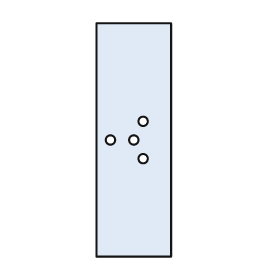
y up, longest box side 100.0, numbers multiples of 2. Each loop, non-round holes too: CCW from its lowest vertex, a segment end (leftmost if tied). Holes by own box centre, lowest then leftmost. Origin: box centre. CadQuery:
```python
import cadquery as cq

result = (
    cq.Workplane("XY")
    .moveTo(-16.0, -50.0)
    .lineTo(16.0, -50.0)
    .lineTo(16.0, 50.0)
    .lineTo(-16.0, 50.0)
    .close()
    .moveTo(4.0, -8.0)
    .circle(2.0)
    .moveTo(-10.0, 0.0)
    .circle(2.0)
    .moveTo(0.0, 0.0)
    .circle(2.0)
    .moveTo(4.0, 8.0)
    .circle(2.0)
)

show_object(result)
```